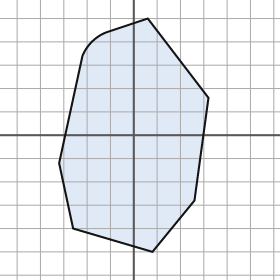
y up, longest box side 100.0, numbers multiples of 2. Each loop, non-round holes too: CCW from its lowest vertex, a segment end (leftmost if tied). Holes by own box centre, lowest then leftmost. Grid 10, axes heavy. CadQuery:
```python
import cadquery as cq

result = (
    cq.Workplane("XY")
    .moveTo(8.0, -50.0)
    .lineTo(26.0, -28.0)
    .lineTo(32.0, 16.0)
    .lineTo(6.0, 50.0)
    .lineTo(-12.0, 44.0)
    .threePointArc((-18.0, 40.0), (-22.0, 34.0))
    .lineTo(-32.0, -12.0)
    .lineTo(-26.0, -40.0)
    .close()
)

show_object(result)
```